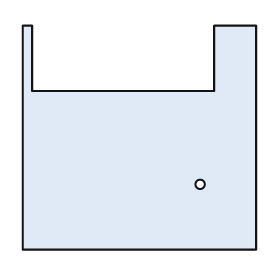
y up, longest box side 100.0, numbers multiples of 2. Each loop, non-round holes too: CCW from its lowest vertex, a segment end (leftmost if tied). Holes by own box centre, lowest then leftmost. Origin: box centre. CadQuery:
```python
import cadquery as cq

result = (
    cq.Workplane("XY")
    .moveTo(-50.0, -48.0)
    .lineTo(50.0, -48.0)
    .lineTo(50.0, 48.0)
    .lineTo(32.0, 48.0)
    .lineTo(32.0, 20.0)
    .lineTo(-46.0, 20.0)
    .lineTo(-46.0, 48.0)
    .lineTo(-50.0, 48.0)
    .close()
    .moveTo(26.0, -20.0)
    .circle(2.0)
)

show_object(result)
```